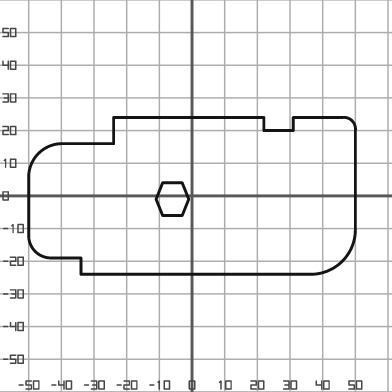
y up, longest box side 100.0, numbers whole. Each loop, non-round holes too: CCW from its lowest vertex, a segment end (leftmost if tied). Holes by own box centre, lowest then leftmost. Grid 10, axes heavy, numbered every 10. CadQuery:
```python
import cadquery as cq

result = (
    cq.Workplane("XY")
    .moveTo(-34.0, -24.0)
    .lineTo(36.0, -24.0)
    .threePointArc((46.0, -20.0), (50.0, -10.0))
    .lineTo(50.0, 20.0)
    .threePointArc((49.0, 23.0), (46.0, 24.0))
    .lineTo(31.0, 24.0)
    .lineTo(31.0, 20.0)
    .lineTo(22.0, 20.0)
    .lineTo(22.0, 24.0)
    .lineTo(-24.0, 24.0)
    .lineTo(-24.0, 16.0)
    .lineTo(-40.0, 16.0)
    .threePointArc((-47.0, 13.0), (-50.0, 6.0))
    .lineTo(-50.0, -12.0)
    .threePointArc((-48.0, -17.0), (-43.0, -19.0))
    .lineTo(-34.0, -19.0)
    .close()
    .moveTo(-9.0, -6.0)
    .lineTo(-3.0, -6.0)
    .lineTo(-1.0, -1.0)
    .lineTo(-3.0, 4.0)
    .lineTo(-9.0, 4.0)
    .lineTo(-11.0, -1.0)
    .close()
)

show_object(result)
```